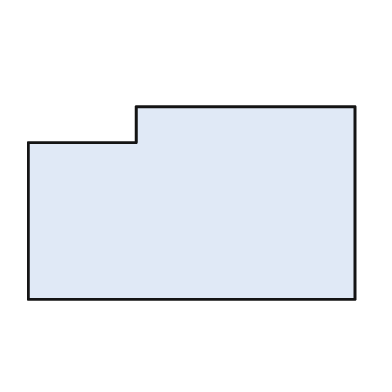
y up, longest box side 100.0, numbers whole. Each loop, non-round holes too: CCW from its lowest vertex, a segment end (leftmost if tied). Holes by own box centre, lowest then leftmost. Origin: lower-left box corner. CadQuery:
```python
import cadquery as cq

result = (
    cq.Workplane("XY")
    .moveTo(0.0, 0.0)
    .lineTo(100.0, 0.0)
    .lineTo(100.0, 59.0)
    .lineTo(33.0, 59.0)
    .lineTo(33.0, 48.0)
    .lineTo(0.0, 48.0)
    .close()
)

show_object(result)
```